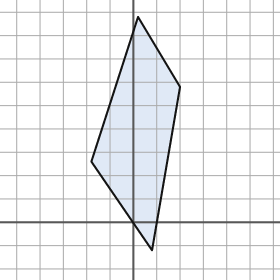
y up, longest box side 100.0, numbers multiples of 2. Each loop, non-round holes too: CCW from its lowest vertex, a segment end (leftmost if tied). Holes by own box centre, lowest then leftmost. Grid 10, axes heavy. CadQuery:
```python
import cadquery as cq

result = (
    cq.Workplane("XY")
    .moveTo(8.0, -12.0)
    .lineTo(20.0, 58.0)
    .lineTo(2.0, 88.0)
    .lineTo(-18.0, 26.0)
    .close()
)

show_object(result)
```